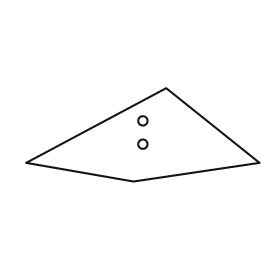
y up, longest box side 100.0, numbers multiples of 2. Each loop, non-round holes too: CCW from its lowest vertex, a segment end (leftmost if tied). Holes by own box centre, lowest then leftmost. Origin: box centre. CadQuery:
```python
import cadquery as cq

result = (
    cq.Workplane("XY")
    .moveTo(-4.0, -20.0)
    .lineTo(50.0, -12.0)
    .lineTo(10.0, 20.0)
    .lineTo(-50.0, -12.0)
    .close()
    .moveTo(0.0, -4.0)
    .circle(2.0)
    .moveTo(0.0, 6.0)
    .circle(2.0)
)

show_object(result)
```